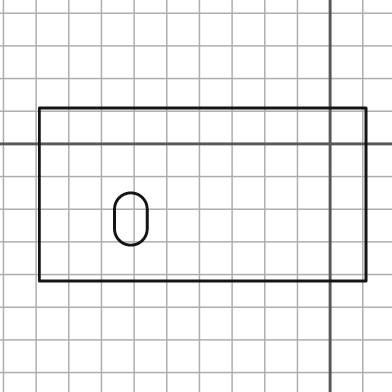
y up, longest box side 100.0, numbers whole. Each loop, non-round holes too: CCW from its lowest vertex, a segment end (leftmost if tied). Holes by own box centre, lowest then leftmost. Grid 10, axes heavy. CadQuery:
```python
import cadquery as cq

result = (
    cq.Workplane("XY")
    .moveTo(-89.0, -42.0)
    .lineTo(11.0, -42.0)
    .lineTo(11.0, 11.0)
    .lineTo(-89.0, 11.0)
    .close()
    .moveTo(-66.0, -26.0)
    .threePointArc((-61.0, -31.0), (-56.0, -26.0))
    .lineTo(-56.0, -20.0)
    .threePointArc((-61.0, -15.0), (-66.0, -20.0))
    .close()
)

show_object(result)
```